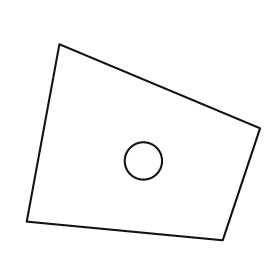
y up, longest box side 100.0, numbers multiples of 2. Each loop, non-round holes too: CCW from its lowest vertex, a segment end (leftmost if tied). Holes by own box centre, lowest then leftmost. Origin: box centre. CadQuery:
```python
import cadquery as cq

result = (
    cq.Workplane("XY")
    .moveTo(34.0, -42.0)
    .lineTo(50.0, 6.0)
    .lineTo(-36.0, 42.0)
    .lineTo(-50.0, -34.0)
    .close()
    .moveTo(0.0, -8.0)
    .circle(8.0)
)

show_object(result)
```